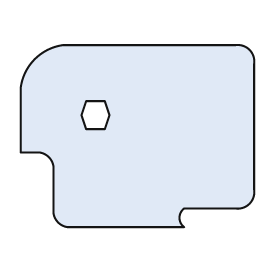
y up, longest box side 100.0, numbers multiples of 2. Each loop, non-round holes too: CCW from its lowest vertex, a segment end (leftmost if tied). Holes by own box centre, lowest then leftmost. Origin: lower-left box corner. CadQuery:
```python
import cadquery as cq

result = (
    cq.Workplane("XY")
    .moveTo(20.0, 0.0)
    .lineTo(70.0, 0.0)
    .threePointArc((68.0, 4.0), (70.0, 8.0))
    .lineTo(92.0, 8.0)
    .threePointArc((98.0, 10.0), (100.0, 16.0))
    .lineTo(100.0, 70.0)
    .threePointArc((98.0, 76.0), (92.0, 78.0))
    .lineTo(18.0, 78.0)
    .threePointArc((6.0, 72.0), (0.0, 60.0))
    .lineTo(0.0, 32.0)
    .lineTo(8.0, 32.0)
    .threePointArc((12.0, 30.0), (14.0, 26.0))
    .lineTo(14.0, 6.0)
    .threePointArc((16.0, 2.0), (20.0, 0.0))
    .close()
    .moveTo(28.0, 42.0)
    .lineTo(36.0, 42.0)
    .lineTo(38.0, 48.0)
    .lineTo(36.0, 54.0)
    .lineTo(28.0, 54.0)
    .lineTo(26.0, 48.0)
    .close()
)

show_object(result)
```